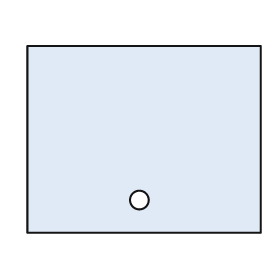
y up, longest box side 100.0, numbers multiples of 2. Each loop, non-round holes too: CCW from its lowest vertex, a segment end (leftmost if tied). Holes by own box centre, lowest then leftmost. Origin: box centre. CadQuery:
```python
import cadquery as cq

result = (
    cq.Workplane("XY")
    .moveTo(-50.0, -40.0)
    .lineTo(50.0, -40.0)
    .lineTo(50.0, 40.0)
    .lineTo(-50.0, 40.0)
    .close()
    .moveTo(-2.0, -26.0)
    .circle(4.0)
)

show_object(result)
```